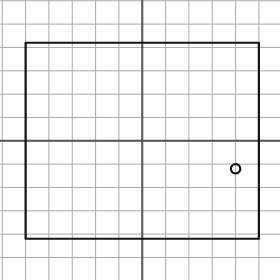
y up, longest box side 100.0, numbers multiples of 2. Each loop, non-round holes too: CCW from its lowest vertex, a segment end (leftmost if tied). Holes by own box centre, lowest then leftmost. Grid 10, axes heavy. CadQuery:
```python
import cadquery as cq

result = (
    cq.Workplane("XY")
    .moveTo(-50.0, -42.0)
    .lineTo(50.0, -42.0)
    .lineTo(50.0, 42.0)
    .lineTo(-50.0, 42.0)
    .close()
    .moveTo(40.0, -12.0)
    .circle(2.0)
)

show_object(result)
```